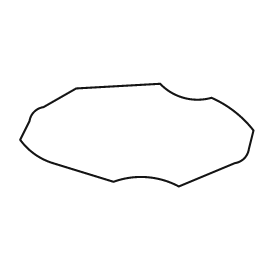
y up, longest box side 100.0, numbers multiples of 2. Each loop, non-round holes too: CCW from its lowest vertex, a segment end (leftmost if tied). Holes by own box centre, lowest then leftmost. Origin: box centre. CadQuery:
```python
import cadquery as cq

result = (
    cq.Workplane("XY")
    .moveTo(18.0, -22.0)
    .lineTo(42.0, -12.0)
    .threePointArc((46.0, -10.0), (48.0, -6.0))
    .lineTo(50.0, 2.0)
    .threePointArc((42.0, 10.0), (32.0, 16.0))
    .threePointArc((20.0, 16.0), (10.0, 22.0))
    .lineTo(-26.0, 20.0)
    .lineTo(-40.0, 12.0)
    .threePointArc((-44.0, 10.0), (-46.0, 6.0))
    .lineTo(-50.0, -2.0)
    .threePointArc((-44.0, -8.0), (-36.0, -12.0))
    .lineTo(-10.0, -20.0)
    .threePointArc((4.0, -18.0), (18.0, -22.0))
    .close()
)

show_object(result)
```